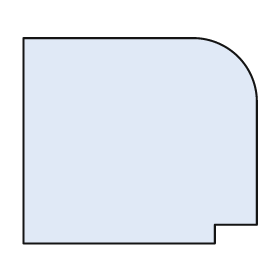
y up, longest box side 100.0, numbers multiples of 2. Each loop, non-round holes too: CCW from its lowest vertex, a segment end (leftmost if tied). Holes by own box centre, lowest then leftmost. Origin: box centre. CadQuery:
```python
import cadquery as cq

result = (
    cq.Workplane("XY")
    .moveTo(-50.0, -44.0)
    .lineTo(32.0, -44.0)
    .lineTo(32.0, -36.0)
    .lineTo(50.0, -36.0)
    .lineTo(50.0, 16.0)
    .threePointArc((42.0, 36.0), (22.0, 44.0))
    .lineTo(-50.0, 44.0)
    .close()
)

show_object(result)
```